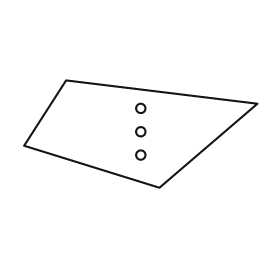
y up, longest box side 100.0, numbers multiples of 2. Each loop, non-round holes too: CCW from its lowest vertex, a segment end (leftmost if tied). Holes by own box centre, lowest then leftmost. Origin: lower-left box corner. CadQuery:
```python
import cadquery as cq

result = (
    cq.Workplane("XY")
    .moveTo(58.0, 0.0)
    .lineTo(100.0, 36.0)
    .lineTo(18.0, 46.0)
    .lineTo(0.0, 18.0)
    .close()
    .moveTo(50.0, 14.0)
    .circle(2.0)
    .moveTo(50.0, 24.0)
    .circle(2.0)
    .moveTo(50.0, 34.0)
    .circle(2.0)
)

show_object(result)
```